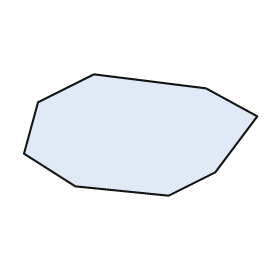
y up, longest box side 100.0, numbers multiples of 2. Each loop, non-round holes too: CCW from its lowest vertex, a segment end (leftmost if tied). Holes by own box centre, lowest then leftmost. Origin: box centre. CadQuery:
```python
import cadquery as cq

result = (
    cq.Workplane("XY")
    .moveTo(12.0, -26.0)
    .lineTo(32.0, -16.0)
    .lineTo(50.0, 8.0)
    .lineTo(28.0, 20.0)
    .lineTo(-20.0, 26.0)
    .lineTo(-44.0, 14.0)
    .lineTo(-50.0, -8.0)
    .lineTo(-28.0, -22.0)
    .close()
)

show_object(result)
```